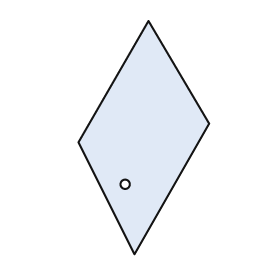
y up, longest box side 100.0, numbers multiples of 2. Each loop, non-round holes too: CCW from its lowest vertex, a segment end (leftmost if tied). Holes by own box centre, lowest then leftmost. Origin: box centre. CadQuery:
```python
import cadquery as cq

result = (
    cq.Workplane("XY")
    .moveTo(-4.0, -50.0)
    .lineTo(28.0, 6.0)
    .lineTo(2.0, 50.0)
    .lineTo(-28.0, -2.0)
    .close()
    .moveTo(-8.0, -20.0)
    .circle(2.0)
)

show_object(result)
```